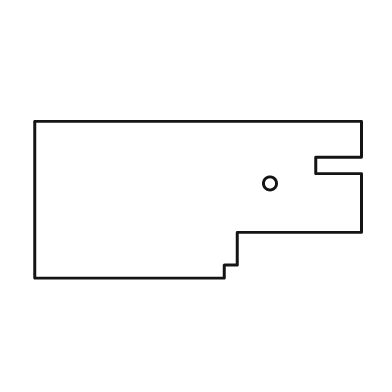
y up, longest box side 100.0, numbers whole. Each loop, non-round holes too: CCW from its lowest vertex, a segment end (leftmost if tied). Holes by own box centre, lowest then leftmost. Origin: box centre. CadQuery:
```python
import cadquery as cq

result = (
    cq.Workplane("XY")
    .moveTo(-50.0, -24.0)
    .lineTo(8.0, -24.0)
    .lineTo(8.0, -20.0)
    .lineTo(12.0, -20.0)
    .lineTo(12.0, -10.0)
    .lineTo(50.0, -10.0)
    .lineTo(50.0, 8.0)
    .lineTo(36.0, 8.0)
    .lineTo(36.0, 13.0)
    .lineTo(50.0, 13.0)
    .lineTo(50.0, 24.0)
    .lineTo(-50.0, 24.0)
    .close()
    .moveTo(22.0, 5.0)
    .circle(2.0)
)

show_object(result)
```